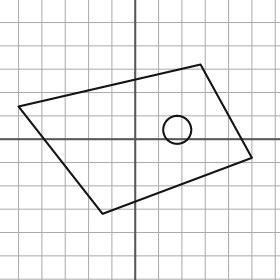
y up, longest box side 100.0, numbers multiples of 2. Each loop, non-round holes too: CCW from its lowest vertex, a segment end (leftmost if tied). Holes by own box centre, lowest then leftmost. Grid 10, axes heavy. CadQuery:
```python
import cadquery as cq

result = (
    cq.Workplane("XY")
    .moveTo(-14.0, -32.0)
    .lineTo(50.0, -8.0)
    .lineTo(28.0, 32.0)
    .lineTo(-50.0, 14.0)
    .close()
    .moveTo(18.0, 4.0)
    .circle(6.0)
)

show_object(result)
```